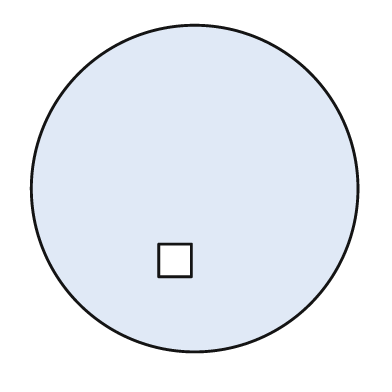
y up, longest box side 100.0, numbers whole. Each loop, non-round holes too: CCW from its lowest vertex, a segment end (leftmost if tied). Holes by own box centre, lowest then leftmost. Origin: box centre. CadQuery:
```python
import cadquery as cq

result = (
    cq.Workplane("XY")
    .moveTo(0.0, 0.0)
    .circle(50.0)
    .moveTo(-11.0, -27.0)
    .lineTo(-1.0, -27.0)
    .lineTo(-1.0, -17.0)
    .lineTo(-11.0, -17.0)
    .close()
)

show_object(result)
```